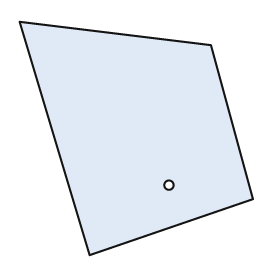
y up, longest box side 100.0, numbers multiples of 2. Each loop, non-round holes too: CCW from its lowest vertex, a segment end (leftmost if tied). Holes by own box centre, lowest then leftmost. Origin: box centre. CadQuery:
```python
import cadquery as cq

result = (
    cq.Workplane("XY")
    .moveTo(-20.0, -50.0)
    .lineTo(50.0, -26.0)
    .lineTo(32.0, 40.0)
    .lineTo(-50.0, 50.0)
    .close()
    .moveTo(14.0, -20.0)
    .circle(2.0)
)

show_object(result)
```